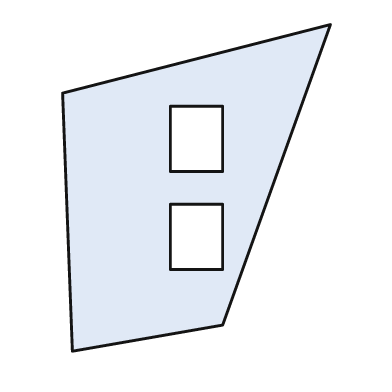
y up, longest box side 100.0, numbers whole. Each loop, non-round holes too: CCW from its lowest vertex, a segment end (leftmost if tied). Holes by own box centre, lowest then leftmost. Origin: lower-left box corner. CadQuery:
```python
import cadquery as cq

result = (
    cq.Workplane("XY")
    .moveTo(3.0, 0.0)
    .lineTo(49.0, 8.0)
    .lineTo(82.0, 100.0)
    .lineTo(0.0, 79.0)
    .close()
    .moveTo(33.0, 25.0)
    .lineTo(49.0, 25.0)
    .lineTo(49.0, 45.0)
    .lineTo(33.0, 45.0)
    .close()
    .moveTo(33.0, 55.0)
    .lineTo(49.0, 55.0)
    .lineTo(49.0, 75.0)
    .lineTo(33.0, 75.0)
    .close()
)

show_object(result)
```